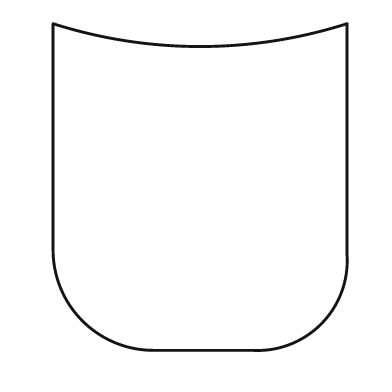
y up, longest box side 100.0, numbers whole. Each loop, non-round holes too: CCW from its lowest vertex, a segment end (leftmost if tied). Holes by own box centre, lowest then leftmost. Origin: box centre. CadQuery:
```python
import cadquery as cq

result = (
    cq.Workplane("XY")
    .moveTo(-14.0, -50.0)
    .lineTo(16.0, -50.0)
    .threePointArc((37.0, -42.0), (45.0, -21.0))
    .lineTo(45.0, 50.0)
    .threePointArc((0.0, 43.0), (-45.0, 50.0))
    .lineTo(-45.0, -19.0)
    .threePointArc((-36.0, -41.0), (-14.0, -50.0))
    .close()
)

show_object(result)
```